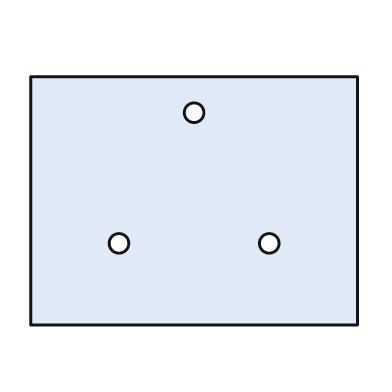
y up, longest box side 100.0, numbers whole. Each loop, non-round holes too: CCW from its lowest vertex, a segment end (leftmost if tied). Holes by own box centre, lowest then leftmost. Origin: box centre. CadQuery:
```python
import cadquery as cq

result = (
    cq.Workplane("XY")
    .moveTo(-50.0, -38.0)
    .lineTo(50.0, -38.0)
    .lineTo(50.0, 38.0)
    .lineTo(-50.0, 38.0)
    .close()
    .moveTo(-23.0, -13.0)
    .circle(3.0)
    .moveTo(23.0, -13.0)
    .circle(3.0)
    .moveTo(0.0, 27.0)
    .circle(3.0)
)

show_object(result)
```